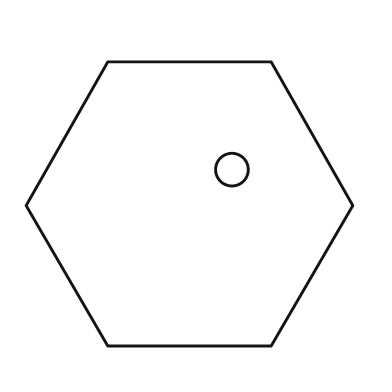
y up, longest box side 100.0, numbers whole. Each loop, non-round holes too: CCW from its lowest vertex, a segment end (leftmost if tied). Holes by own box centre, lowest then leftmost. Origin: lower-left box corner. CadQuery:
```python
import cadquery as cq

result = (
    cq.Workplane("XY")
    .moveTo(25.0, 0.0)
    .lineTo(75.0, 0.0)
    .lineTo(100.0, 43.0)
    .lineTo(75.0, 87.0)
    .lineTo(25.0, 87.0)
    .lineTo(0.0, 43.0)
    .close()
    .moveTo(63.0, 54.0)
    .circle(5.0)
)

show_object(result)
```